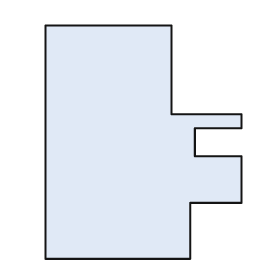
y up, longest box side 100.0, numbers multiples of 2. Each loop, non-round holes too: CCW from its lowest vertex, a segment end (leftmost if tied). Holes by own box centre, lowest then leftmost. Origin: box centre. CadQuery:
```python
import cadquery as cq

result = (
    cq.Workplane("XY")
    .moveTo(-42.0, -50.0)
    .lineTo(20.0, -50.0)
    .lineTo(20.0, -26.0)
    .lineTo(42.0, -26.0)
    .lineTo(42.0, -6.0)
    .lineTo(22.0, -6.0)
    .lineTo(22.0, 6.0)
    .lineTo(42.0, 6.0)
    .lineTo(42.0, 12.0)
    .lineTo(12.0, 12.0)
    .lineTo(12.0, 50.0)
    .lineTo(-42.0, 50.0)
    .close()
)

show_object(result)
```